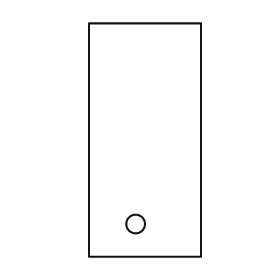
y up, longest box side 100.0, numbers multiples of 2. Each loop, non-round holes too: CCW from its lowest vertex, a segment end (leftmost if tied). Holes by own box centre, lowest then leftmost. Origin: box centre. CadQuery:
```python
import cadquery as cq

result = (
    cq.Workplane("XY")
    .moveTo(-24.0, -50.0)
    .lineTo(24.0, -50.0)
    .lineTo(24.0, 50.0)
    .lineTo(-24.0, 50.0)
    .close()
    .moveTo(-4.0, -36.0)
    .circle(4.0)
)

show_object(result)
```